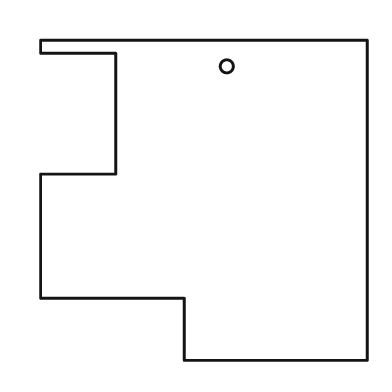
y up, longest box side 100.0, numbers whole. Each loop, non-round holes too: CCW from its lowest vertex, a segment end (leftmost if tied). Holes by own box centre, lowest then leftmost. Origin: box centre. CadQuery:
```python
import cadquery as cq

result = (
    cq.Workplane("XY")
    .moveTo(-6.0, -49.0)
    .lineTo(50.0, -49.0)
    .lineTo(50.0, 49.0)
    .lineTo(-50.0, 49.0)
    .lineTo(-50.0, 45.0)
    .lineTo(-27.0, 45.0)
    .lineTo(-27.0, 8.0)
    .lineTo(-50.0, 8.0)
    .lineTo(-50.0, -30.0)
    .lineTo(-6.0, -30.0)
    .close()
    .moveTo(7.0, 41.0)
    .circle(2.0)
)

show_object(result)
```